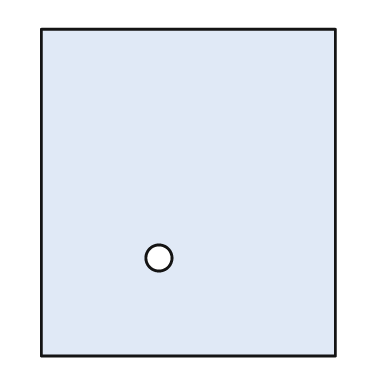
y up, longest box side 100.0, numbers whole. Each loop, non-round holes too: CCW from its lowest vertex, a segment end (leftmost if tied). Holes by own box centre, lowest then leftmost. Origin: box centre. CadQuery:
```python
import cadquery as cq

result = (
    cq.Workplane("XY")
    .moveTo(-45.0, -50.0)
    .lineTo(45.0, -50.0)
    .lineTo(45.0, 50.0)
    .lineTo(-45.0, 50.0)
    .close()
    .moveTo(-9.0, -20.0)
    .circle(4.0)
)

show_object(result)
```